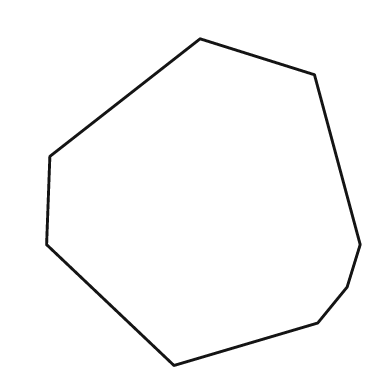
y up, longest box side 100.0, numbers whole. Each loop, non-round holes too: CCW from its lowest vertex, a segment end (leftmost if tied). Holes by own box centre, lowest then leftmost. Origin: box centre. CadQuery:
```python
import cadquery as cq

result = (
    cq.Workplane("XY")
    .moveTo(-9.0, -50.0)
    .lineTo(35.0, -37.0)
    .lineTo(44.0, -26.0)
    .lineTo(48.0, -13.0)
    .lineTo(34.0, 39.0)
    .lineTo(-1.0, 50.0)
    .lineTo(-47.0, 14.0)
    .lineTo(-48.0, -13.0)
    .close()
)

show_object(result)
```